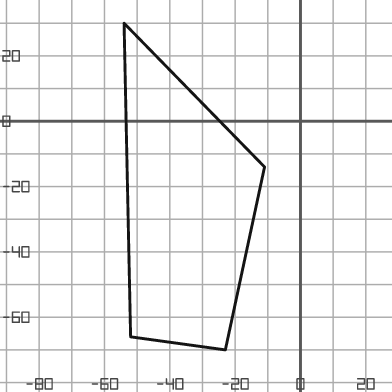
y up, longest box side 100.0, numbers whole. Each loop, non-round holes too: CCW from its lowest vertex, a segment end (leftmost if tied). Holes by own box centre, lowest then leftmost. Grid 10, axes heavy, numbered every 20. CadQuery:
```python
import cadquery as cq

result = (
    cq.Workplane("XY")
    .moveTo(-23.0, -70.0)
    .lineTo(-11.0, -14.0)
    .lineTo(-54.0, 30.0)
    .lineTo(-52.0, -66.0)
    .close()
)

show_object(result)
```